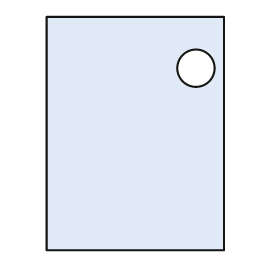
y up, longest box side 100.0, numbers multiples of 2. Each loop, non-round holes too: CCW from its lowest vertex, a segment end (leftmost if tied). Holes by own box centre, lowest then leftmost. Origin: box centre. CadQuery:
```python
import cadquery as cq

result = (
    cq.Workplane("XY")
    .moveTo(-38.0, -50.0)
    .lineTo(38.0, -50.0)
    .lineTo(38.0, 50.0)
    .lineTo(-38.0, 50.0)
    .close()
    .moveTo(26.0, 28.0)
    .circle(8.0)
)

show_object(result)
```